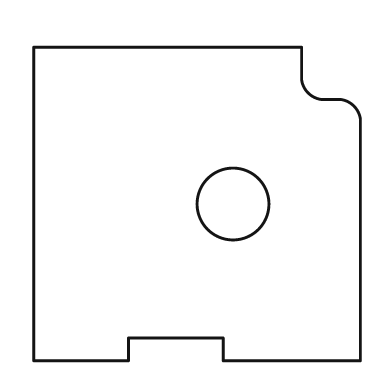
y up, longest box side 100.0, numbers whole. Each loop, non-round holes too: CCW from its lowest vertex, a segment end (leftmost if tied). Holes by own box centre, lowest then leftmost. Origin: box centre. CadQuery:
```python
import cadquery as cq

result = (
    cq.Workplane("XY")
    .moveTo(-50.0, -48.0)
    .lineTo(-21.0, -48.0)
    .lineTo(-21.0, -41.0)
    .lineTo(8.0, -41.0)
    .lineTo(8.0, -48.0)
    .lineTo(50.0, -48.0)
    .lineTo(50.0, 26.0)
    .threePointArc((48.0, 30.0), (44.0, 32.0))
    .lineTo(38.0, 32.0)
    .threePointArc((34.0, 34.0), (32.0, 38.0))
    .lineTo(32.0, 48.0)
    .lineTo(-50.0, 48.0)
    .close()
    .moveTo(11.0, 0.0)
    .circle(11.0)
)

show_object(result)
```